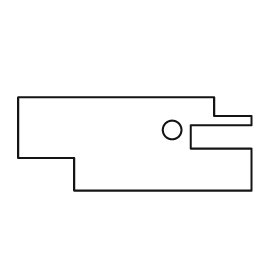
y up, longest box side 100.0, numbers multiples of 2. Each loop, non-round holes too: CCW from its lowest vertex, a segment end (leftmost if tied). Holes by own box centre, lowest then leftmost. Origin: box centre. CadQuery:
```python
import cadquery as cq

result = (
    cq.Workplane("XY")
    .moveTo(-26.0, -20.0)
    .lineTo(50.0, -20.0)
    .lineTo(50.0, -2.0)
    .lineTo(24.0, -2.0)
    .lineTo(24.0, 8.0)
    .lineTo(50.0, 8.0)
    .lineTo(50.0, 12.0)
    .lineTo(34.0, 12.0)
    .lineTo(34.0, 20.0)
    .lineTo(-50.0, 20.0)
    .lineTo(-50.0, -6.0)
    .lineTo(-26.0, -6.0)
    .close()
    .moveTo(16.0, 6.0)
    .circle(4.0)
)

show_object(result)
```